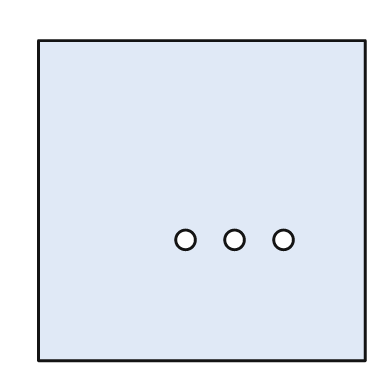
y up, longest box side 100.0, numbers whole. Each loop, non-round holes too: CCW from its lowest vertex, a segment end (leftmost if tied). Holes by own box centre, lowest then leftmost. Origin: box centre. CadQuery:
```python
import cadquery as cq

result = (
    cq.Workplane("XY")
    .moveTo(-50.0, -49.0)
    .lineTo(50.0, -49.0)
    .lineTo(50.0, 49.0)
    .lineTo(-50.0, 49.0)
    .close()
    .moveTo(-5.0, -12.0)
    .circle(3.0)
    .moveTo(10.0, -12.0)
    .circle(3.0)
    .moveTo(25.0, -12.0)
    .circle(3.0)
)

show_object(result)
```